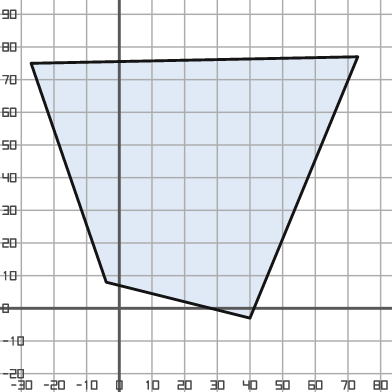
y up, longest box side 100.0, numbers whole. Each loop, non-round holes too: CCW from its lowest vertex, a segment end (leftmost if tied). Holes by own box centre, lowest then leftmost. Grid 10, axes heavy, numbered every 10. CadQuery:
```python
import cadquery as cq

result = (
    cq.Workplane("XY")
    .moveTo(40.0, -3.0)
    .lineTo(73.0, 77.0)
    .lineTo(-27.0, 75.0)
    .lineTo(-4.0, 8.0)
    .close()
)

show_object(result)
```